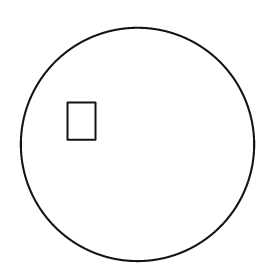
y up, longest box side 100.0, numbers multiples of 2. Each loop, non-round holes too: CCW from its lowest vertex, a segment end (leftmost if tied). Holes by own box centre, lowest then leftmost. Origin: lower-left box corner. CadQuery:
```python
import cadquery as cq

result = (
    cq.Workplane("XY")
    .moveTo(50.0, 50.0)
    .circle(50.0)
    .moveTo(20.0, 52.0)
    .lineTo(32.0, 52.0)
    .lineTo(32.0, 68.0)
    .lineTo(20.0, 68.0)
    .close()
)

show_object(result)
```